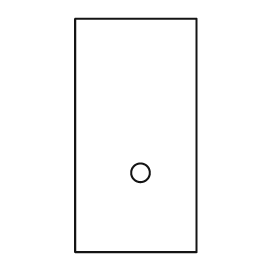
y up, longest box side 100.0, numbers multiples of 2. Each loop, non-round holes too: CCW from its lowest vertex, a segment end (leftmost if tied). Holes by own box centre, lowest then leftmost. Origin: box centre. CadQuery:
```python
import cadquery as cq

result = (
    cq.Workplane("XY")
    .moveTo(-26.0, -50.0)
    .lineTo(26.0, -50.0)
    .lineTo(26.0, 50.0)
    .lineTo(-26.0, 50.0)
    .close()
    .moveTo(2.0, -16.0)
    .circle(4.0)
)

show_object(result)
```